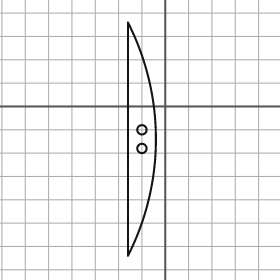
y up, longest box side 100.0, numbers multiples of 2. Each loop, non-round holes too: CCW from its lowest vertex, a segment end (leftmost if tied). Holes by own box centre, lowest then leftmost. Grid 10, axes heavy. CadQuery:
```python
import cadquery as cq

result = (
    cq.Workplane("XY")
    .moveTo(-16.0, -64.0)
    .threePointArc((-4.0, -14.0), (-16.0, 36.0))
    .close()
    .moveTo(-10.0, -18.0)
    .circle(2.0)
    .moveTo(-10.0, -10.0)
    .circle(2.0)
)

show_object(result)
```